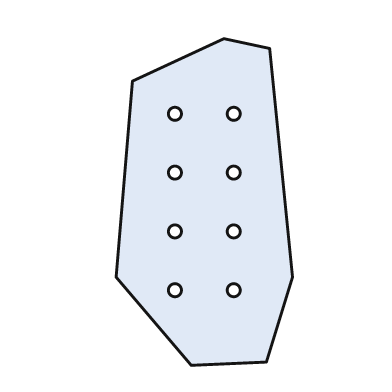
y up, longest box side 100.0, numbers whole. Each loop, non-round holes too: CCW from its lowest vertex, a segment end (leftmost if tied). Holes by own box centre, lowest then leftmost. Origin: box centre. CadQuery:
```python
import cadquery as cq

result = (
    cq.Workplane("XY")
    .moveTo(-4.0, -50.0)
    .lineTo(19.0, -49.0)
    .lineTo(27.0, -23.0)
    .lineTo(20.0, 47.0)
    .lineTo(6.0, 50.0)
    .lineTo(-22.0, 37.0)
    .lineTo(-27.0, -23.0)
    .close()
    .moveTo(-9.0, -27.0)
    .circle(2.0)
    .moveTo(9.0, -27.0)
    .circle(2.0)
    .moveTo(-9.0, -9.0)
    .circle(2.0)
    .moveTo(9.0, -9.0)
    .circle(2.0)
    .moveTo(-9.0, 9.0)
    .circle(2.0)
    .moveTo(9.0, 9.0)
    .circle(2.0)
    .moveTo(-9.0, 27.0)
    .circle(2.0)
    .moveTo(9.0, 27.0)
    .circle(2.0)
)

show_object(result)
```